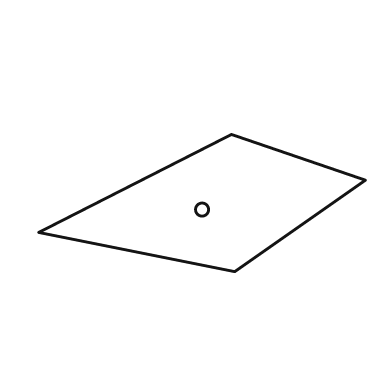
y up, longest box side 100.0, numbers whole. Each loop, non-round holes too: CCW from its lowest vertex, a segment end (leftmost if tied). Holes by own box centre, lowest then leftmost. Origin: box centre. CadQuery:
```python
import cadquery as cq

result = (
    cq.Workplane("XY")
    .moveTo(10.0, -21.0)
    .lineTo(50.0, 7.0)
    .lineTo(9.0, 21.0)
    .lineTo(-50.0, -9.0)
    .close()
    .moveTo(0.0, -2.0)
    .circle(2.0)
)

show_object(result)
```